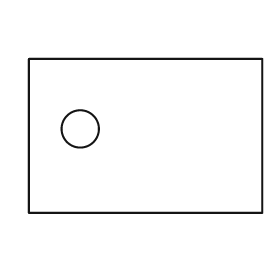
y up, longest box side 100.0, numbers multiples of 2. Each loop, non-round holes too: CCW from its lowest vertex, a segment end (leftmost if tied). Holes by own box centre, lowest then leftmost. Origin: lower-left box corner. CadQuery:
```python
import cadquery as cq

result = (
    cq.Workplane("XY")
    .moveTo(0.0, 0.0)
    .lineTo(100.0, 0.0)
    .lineTo(100.0, 66.0)
    .lineTo(0.0, 66.0)
    .close()
    .moveTo(22.0, 36.0)
    .circle(8.0)
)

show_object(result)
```